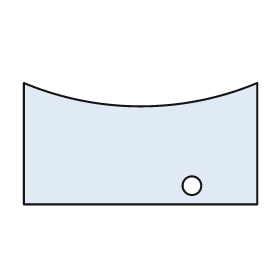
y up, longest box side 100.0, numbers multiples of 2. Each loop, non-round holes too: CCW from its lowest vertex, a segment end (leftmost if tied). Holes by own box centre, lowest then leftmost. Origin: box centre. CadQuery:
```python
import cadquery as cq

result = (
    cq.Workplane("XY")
    .moveTo(-50.0, -26.0)
    .lineTo(50.0, -26.0)
    .lineTo(50.0, 26.0)
    .threePointArc((0.0, 16.0), (-50.0, 26.0))
    .close()
    .moveTo(22.0, -18.0)
    .circle(4.0)
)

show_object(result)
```